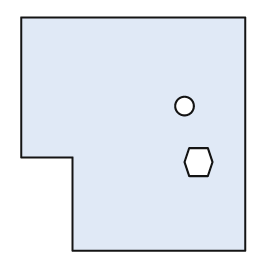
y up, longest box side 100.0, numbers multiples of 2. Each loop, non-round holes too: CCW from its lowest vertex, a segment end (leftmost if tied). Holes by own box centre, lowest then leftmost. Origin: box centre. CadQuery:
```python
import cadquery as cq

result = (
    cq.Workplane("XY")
    .moveTo(-26.0, -50.0)
    .lineTo(48.0, -50.0)
    .lineTo(48.0, 50.0)
    .lineTo(-48.0, 50.0)
    .lineTo(-48.0, -10.0)
    .lineTo(-26.0, -10.0)
    .close()
    .moveTo(24.0, -18.0)
    .lineTo(32.0, -18.0)
    .lineTo(34.0, -12.0)
    .lineTo(32.0, -6.0)
    .lineTo(24.0, -6.0)
    .lineTo(22.0, -12.0)
    .close()
    .moveTo(22.0, 12.0)
    .circle(4.0)
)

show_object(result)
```